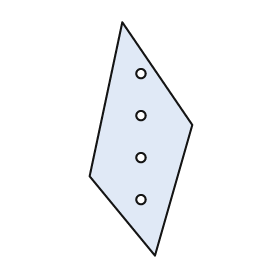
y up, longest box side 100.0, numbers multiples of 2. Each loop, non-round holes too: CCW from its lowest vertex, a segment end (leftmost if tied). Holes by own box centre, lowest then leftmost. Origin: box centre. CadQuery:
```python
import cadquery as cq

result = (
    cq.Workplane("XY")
    .moveTo(6.0, -50.0)
    .lineTo(22.0, 6.0)
    .lineTo(-8.0, 50.0)
    .lineTo(-22.0, -16.0)
    .close()
    .moveTo(0.0, -26.0)
    .circle(2.0)
    .moveTo(0.0, -8.0)
    .circle(2.0)
    .moveTo(0.0, 10.0)
    .circle(2.0)
    .moveTo(0.0, 28.0)
    .circle(2.0)
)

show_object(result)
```